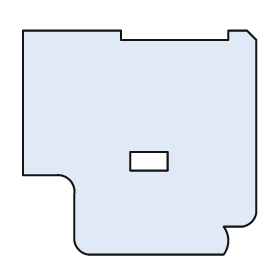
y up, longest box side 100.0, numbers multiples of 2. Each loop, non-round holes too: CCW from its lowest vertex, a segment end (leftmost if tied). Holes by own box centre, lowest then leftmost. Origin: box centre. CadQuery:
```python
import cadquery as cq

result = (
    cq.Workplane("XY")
    .moveTo(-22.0, -48.0)
    .lineTo(36.0, -48.0)
    .threePointArc((38.0, -42.0), (36.0, -36.0))
    .lineTo(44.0, -36.0)
    .threePointArc((48.0, -34.0), (50.0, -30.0))
    .lineTo(50.0, 44.0)
    .lineTo(46.0, 48.0)
    .lineTo(38.0, 48.0)
    .lineTo(38.0, 44.0)
    .lineTo(-8.0, 44.0)
    .lineTo(-8.0, 48.0)
    .lineTo(-50.0, 48.0)
    .lineTo(-50.0, -14.0)
    .lineTo(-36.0, -14.0)
    .threePointArc((-30.0, -16.0), (-28.0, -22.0))
    .lineTo(-28.0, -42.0)
    .threePointArc((-26.0, -46.0), (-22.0, -48.0))
    .close()
    .moveTo(-4.0, -12.0)
    .lineTo(12.0, -12.0)
    .lineTo(12.0, -4.0)
    .lineTo(-4.0, -4.0)
    .close()
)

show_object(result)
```